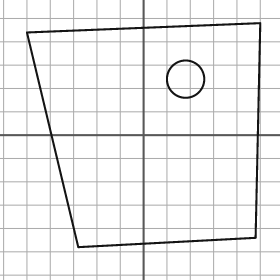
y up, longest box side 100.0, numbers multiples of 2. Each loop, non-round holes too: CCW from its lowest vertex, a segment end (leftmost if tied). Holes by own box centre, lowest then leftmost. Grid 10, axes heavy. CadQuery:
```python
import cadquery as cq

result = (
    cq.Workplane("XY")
    .moveTo(-28.0, -48.0)
    .lineTo(48.0, -44.0)
    .lineTo(50.0, 48.0)
    .lineTo(-50.0, 44.0)
    .close()
    .moveTo(18.0, 24.0)
    .circle(8.0)
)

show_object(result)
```